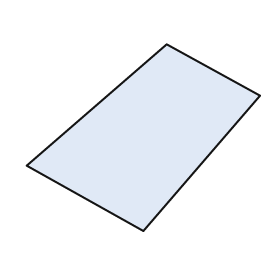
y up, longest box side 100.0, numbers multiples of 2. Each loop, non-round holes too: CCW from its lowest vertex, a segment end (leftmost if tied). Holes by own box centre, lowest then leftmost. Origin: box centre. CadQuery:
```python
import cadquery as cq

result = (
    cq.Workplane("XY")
    .moveTo(0.0, -40.0)
    .lineTo(50.0, 18.0)
    .lineTo(10.0, 40.0)
    .lineTo(-50.0, -12.0)
    .close()
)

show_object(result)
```